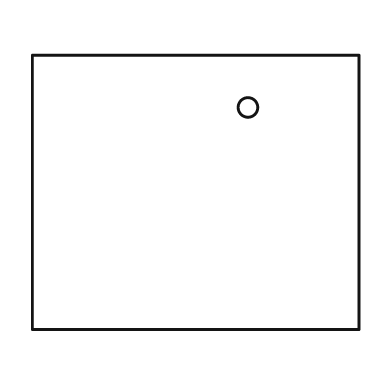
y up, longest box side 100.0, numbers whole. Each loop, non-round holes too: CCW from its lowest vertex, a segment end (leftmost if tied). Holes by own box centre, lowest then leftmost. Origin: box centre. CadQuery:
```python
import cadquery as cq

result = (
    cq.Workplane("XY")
    .moveTo(-50.0, -42.0)
    .lineTo(50.0, -42.0)
    .lineTo(50.0, 42.0)
    .lineTo(-50.0, 42.0)
    .close()
    .moveTo(16.0, 26.0)
    .circle(3.0)
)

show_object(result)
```